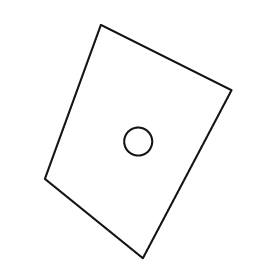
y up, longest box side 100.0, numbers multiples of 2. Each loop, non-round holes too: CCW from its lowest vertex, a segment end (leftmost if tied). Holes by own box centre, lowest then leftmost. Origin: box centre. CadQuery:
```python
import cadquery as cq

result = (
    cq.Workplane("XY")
    .moveTo(2.0, -50.0)
    .lineTo(40.0, 22.0)
    .lineTo(-16.0, 50.0)
    .lineTo(-40.0, -16.0)
    .close()
    .moveTo(0.0, 0.0)
    .circle(6.0)
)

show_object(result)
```